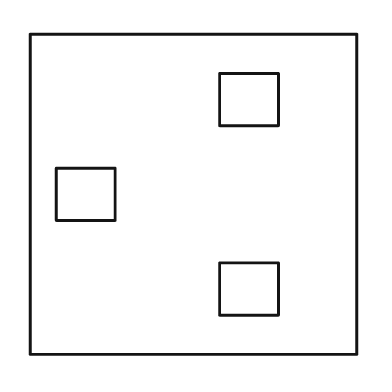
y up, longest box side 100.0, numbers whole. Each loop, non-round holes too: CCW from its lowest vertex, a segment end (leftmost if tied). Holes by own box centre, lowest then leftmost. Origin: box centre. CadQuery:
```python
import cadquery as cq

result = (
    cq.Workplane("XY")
    .moveTo(-50.0, -49.0)
    .lineTo(50.0, -49.0)
    .lineTo(50.0, 49.0)
    .lineTo(-50.0, 49.0)
    .close()
    .moveTo(8.0, -37.0)
    .lineTo(26.0, -37.0)
    .lineTo(26.0, -21.0)
    .lineTo(8.0, -21.0)
    .close()
    .moveTo(-42.0, -8.0)
    .lineTo(-24.0, -8.0)
    .lineTo(-24.0, 8.0)
    .lineTo(-42.0, 8.0)
    .close()
    .moveTo(8.0, 21.0)
    .lineTo(26.0, 21.0)
    .lineTo(26.0, 37.0)
    .lineTo(8.0, 37.0)
    .close()
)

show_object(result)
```